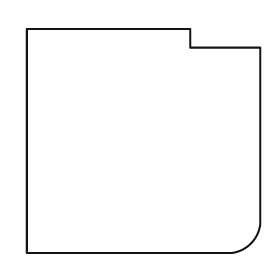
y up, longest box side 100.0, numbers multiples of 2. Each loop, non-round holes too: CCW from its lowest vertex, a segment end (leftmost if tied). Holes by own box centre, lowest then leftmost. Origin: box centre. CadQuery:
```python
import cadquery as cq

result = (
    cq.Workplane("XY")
    .moveTo(-50.0, -48.0)
    .lineTo(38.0, -48.0)
    .threePointArc((46.0, -44.0), (50.0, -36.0))
    .lineTo(50.0, 40.0)
    .lineTo(20.0, 40.0)
    .lineTo(20.0, 48.0)
    .lineTo(-50.0, 48.0)
    .close()
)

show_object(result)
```